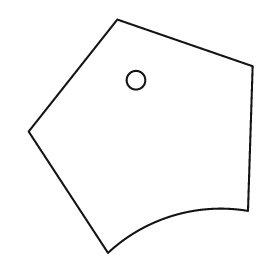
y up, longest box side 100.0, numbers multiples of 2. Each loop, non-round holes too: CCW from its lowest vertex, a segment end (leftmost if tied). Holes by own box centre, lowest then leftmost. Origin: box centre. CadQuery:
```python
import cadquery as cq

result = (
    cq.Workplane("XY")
    .moveTo(-14.0, -50.0)
    .threePointArc((14.0, -34.0), (46.0, -32.0))
    .lineTo(48.0, 30.0)
    .lineTo(-10.0, 50.0)
    .lineTo(-48.0, 2.0)
    .close()
    .moveTo(-2.0, 24.0)
    .circle(4.0)
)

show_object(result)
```